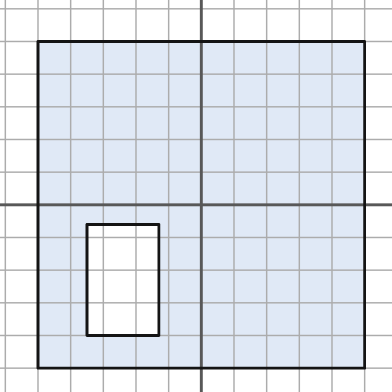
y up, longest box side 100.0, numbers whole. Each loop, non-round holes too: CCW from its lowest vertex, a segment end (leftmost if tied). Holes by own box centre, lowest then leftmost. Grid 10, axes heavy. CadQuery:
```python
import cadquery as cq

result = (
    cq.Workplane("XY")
    .moveTo(-50.0, -50.0)
    .lineTo(50.0, -50.0)
    .lineTo(50.0, 50.0)
    .lineTo(-50.0, 50.0)
    .close()
    .moveTo(-35.0, -40.0)
    .lineTo(-13.0, -40.0)
    .lineTo(-13.0, -6.0)
    .lineTo(-35.0, -6.0)
    .close()
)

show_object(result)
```